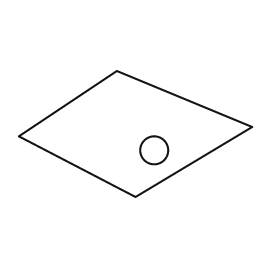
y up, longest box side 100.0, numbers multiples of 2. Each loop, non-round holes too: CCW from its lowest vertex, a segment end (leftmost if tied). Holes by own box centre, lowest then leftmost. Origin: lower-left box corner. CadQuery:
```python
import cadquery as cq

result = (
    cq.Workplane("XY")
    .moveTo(50.0, 0.0)
    .lineTo(100.0, 30.0)
    .lineTo(42.0, 54.0)
    .lineTo(0.0, 26.0)
    .close()
    .moveTo(58.0, 20.0)
    .circle(6.0)
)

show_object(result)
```